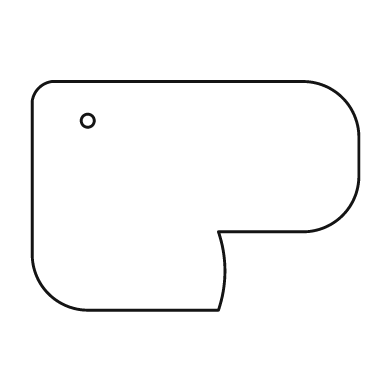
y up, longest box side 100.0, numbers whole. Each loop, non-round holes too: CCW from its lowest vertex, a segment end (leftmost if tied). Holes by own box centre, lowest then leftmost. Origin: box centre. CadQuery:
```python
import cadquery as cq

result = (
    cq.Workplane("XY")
    .moveTo(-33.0, -35.0)
    .lineTo(7.0, -35.0)
    .threePointArc((9.0, -23.0), (7.0, -11.0))
    .lineTo(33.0, -11.0)
    .threePointArc((45.0, -6.0), (50.0, 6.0))
    .lineTo(50.0, 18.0)
    .threePointArc((45.0, 30.0), (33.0, 35.0))
    .lineTo(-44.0, 35.0)
    .threePointArc((-48.0, 33.0), (-50.0, 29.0))
    .lineTo(-50.0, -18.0)
    .threePointArc((-45.0, -30.0), (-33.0, -35.0))
    .close()
    .moveTo(-33.0, 23.0)
    .circle(2.0)
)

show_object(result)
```